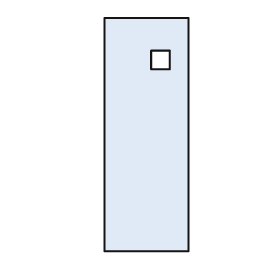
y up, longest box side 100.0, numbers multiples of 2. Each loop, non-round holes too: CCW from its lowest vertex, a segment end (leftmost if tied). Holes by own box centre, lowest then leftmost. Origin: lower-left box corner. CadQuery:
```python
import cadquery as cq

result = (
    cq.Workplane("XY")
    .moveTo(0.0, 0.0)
    .lineTo(36.0, 0.0)
    .lineTo(36.0, 100.0)
    .lineTo(0.0, 100.0)
    .close()
    .moveTo(20.0, 78.0)
    .lineTo(28.0, 78.0)
    .lineTo(28.0, 86.0)
    .lineTo(20.0, 86.0)
    .close()
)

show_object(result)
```